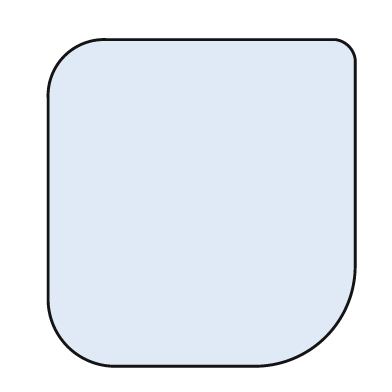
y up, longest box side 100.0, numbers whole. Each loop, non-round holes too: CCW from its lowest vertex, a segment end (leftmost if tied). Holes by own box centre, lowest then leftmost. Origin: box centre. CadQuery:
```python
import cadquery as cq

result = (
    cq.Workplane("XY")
    .moveTo(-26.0, -50.0)
    .lineTo(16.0, -50.0)
    .threePointArc((38.0, -41.0), (47.0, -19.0))
    .lineTo(47.0, 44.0)
    .threePointArc((45.0, 48.0), (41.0, 50.0))
    .lineTo(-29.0, 50.0)
    .threePointArc((-42.0, 45.0), (-47.0, 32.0))
    .lineTo(-47.0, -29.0)
    .threePointArc((-41.0, -44.0), (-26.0, -50.0))
    .close()
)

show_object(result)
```